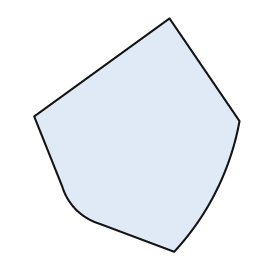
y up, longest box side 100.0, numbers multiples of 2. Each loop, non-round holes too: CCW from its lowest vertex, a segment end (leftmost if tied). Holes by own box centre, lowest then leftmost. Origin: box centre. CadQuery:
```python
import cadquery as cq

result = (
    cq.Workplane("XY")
    .moveTo(16.0, -50.0)
    .threePointArc((34.0, -24.0), (44.0, 6.0))
    .lineTo(14.0, 50.0)
    .lineTo(-44.0, 8.0)
    .lineTo(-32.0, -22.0)
    .threePointArc((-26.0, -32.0), (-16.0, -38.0))
    .close()
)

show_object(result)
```